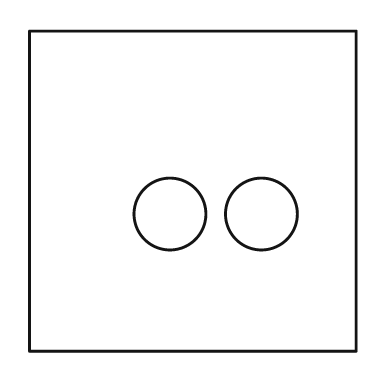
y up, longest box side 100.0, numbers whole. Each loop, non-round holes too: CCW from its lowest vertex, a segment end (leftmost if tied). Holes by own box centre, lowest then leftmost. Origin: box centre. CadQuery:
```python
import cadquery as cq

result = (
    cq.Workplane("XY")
    .moveTo(-50.0, -49.0)
    .lineTo(50.0, -49.0)
    .lineTo(50.0, 49.0)
    .lineTo(-50.0, 49.0)
    .close()
    .moveTo(-7.0, -7.0)
    .circle(11.0)
    .moveTo(21.0, -7.0)
    .circle(11.0)
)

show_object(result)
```